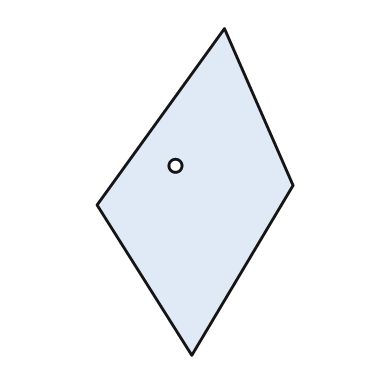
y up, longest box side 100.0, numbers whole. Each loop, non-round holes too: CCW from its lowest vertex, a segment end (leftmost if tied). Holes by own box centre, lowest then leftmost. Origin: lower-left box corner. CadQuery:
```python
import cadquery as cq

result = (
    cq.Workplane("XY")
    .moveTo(29.0, 0.0)
    .lineTo(60.0, 52.0)
    .lineTo(39.0, 100.0)
    .lineTo(0.0, 46.0)
    .close()
    .moveTo(24.0, 58.0)
    .circle(2.0)
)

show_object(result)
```